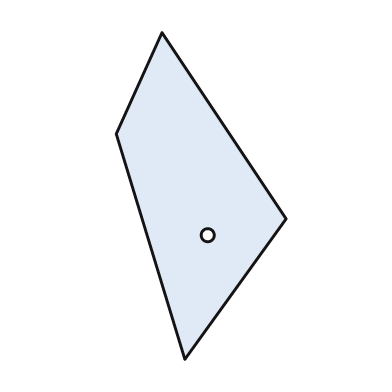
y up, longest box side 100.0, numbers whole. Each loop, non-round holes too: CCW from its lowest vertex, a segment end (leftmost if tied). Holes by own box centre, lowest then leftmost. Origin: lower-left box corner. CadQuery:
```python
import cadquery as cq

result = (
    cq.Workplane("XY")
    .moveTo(21.0, 0.0)
    .lineTo(52.0, 43.0)
    .lineTo(14.0, 100.0)
    .lineTo(0.0, 69.0)
    .close()
    .moveTo(28.0, 38.0)
    .circle(2.0)
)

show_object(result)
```